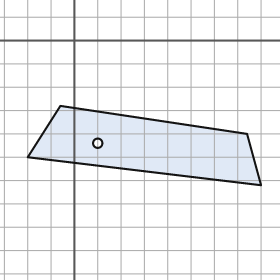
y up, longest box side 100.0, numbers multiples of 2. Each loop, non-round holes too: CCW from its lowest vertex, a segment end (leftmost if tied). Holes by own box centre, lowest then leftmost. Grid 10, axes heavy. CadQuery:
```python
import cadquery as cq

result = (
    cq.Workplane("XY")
    .moveTo(80.0, -62.0)
    .lineTo(74.0, -40.0)
    .lineTo(-6.0, -28.0)
    .lineTo(-20.0, -50.0)
    .close()
    .moveTo(10.0, -44.0)
    .circle(2.0)
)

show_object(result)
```